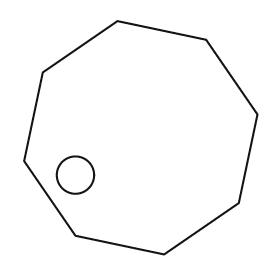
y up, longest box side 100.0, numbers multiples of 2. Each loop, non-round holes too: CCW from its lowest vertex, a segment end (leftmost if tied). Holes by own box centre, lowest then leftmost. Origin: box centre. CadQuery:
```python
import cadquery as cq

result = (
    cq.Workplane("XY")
    .moveTo(10.0, -50.0)
    .lineTo(42.0, -28.0)
    .lineTo(50.0, 10.0)
    .lineTo(28.0, 42.0)
    .lineTo(-10.0, 50.0)
    .lineTo(-42.0, 28.0)
    .lineTo(-50.0, -10.0)
    .lineTo(-28.0, -42.0)
    .close()
    .moveTo(-28.0, -16.0)
    .circle(8.0)
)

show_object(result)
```